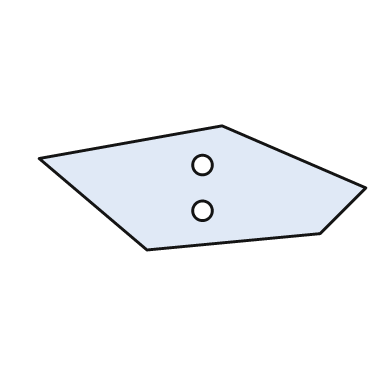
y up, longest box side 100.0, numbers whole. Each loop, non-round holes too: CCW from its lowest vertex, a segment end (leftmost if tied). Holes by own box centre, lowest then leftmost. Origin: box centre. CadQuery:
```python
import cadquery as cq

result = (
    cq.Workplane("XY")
    .moveTo(-17.0, -19.0)
    .lineTo(36.0, -14.0)
    .lineTo(50.0, 0.0)
    .lineTo(6.0, 19.0)
    .lineTo(-50.0, 9.0)
    .close()
    .moveTo(0.0, -7.0)
    .circle(3.0)
    .moveTo(0.0, 7.0)
    .circle(3.0)
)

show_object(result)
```